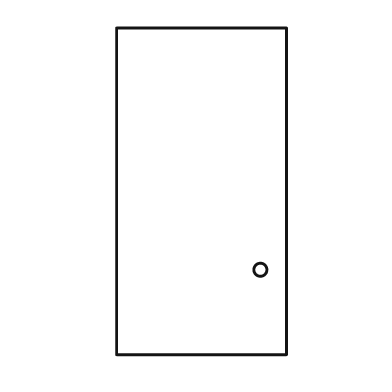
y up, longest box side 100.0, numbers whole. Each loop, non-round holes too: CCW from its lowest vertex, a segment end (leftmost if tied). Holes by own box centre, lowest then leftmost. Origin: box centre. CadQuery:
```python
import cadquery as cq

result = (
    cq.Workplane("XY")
    .moveTo(-26.0, -50.0)
    .lineTo(26.0, -50.0)
    .lineTo(26.0, 50.0)
    .lineTo(-26.0, 50.0)
    .close()
    .moveTo(18.0, -24.0)
    .circle(2.0)
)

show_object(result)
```